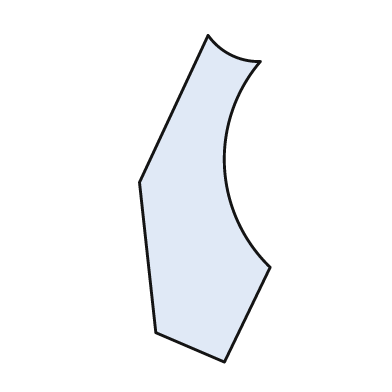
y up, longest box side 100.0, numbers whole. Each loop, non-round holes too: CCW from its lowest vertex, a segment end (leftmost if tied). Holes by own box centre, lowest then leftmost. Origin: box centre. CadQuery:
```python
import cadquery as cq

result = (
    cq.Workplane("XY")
    .moveTo(6.0, -50.0)
    .lineTo(20.0, -21.0)
    .threePointArc((6.0, 10.0), (17.0, 42.0))
    .threePointArc((8.0, 44.0), (1.0, 50.0))
    .lineTo(-20.0, 5.0)
    .lineTo(-15.0, -41.0)
    .close()
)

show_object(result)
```